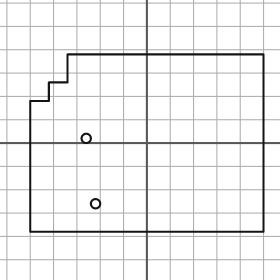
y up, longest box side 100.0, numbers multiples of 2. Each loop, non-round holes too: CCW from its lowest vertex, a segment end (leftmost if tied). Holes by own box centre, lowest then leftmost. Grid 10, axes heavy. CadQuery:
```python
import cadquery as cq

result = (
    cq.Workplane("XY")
    .moveTo(-50.0, -38.0)
    .lineTo(50.0, -38.0)
    .lineTo(50.0, 38.0)
    .lineTo(-34.0, 38.0)
    .lineTo(-34.0, 26.0)
    .lineTo(-42.0, 26.0)
    .lineTo(-42.0, 18.0)
    .lineTo(-50.0, 18.0)
    .close()
    .moveTo(-22.0, -26.0)
    .circle(2.0)
    .moveTo(-26.0, 2.0)
    .circle(2.0)
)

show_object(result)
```